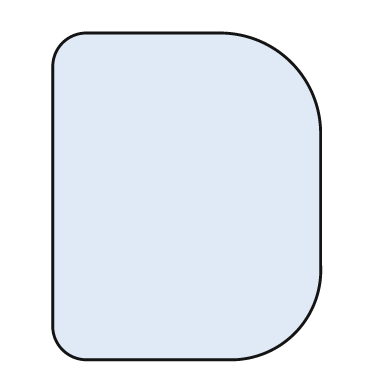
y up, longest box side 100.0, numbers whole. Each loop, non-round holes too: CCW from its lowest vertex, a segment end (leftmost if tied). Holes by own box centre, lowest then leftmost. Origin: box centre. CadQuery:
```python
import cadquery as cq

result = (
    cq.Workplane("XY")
    .moveTo(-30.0, -50.0)
    .lineTo(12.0, -50.0)
    .threePointArc((33.0, -42.0), (41.0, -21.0))
    .lineTo(41.0, 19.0)
    .threePointArc((32.0, 41.0), (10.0, 50.0))
    .lineTo(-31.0, 50.0)
    .threePointArc((-38.0, 47.0), (-41.0, 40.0))
    .lineTo(-41.0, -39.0)
    .threePointArc((-38.0, -47.0), (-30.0, -50.0))
    .close()
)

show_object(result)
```